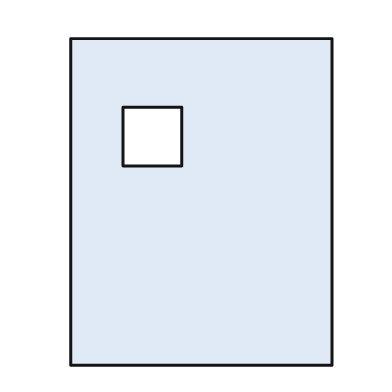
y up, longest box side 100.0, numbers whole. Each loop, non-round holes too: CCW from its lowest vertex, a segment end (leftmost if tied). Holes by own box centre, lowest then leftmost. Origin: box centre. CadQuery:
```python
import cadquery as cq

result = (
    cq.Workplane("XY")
    .moveTo(-40.0, -50.0)
    .lineTo(40.0, -50.0)
    .lineTo(40.0, 50.0)
    .lineTo(-40.0, 50.0)
    .close()
    .moveTo(-24.0, 11.0)
    .lineTo(-6.0, 11.0)
    .lineTo(-6.0, 29.0)
    .lineTo(-24.0, 29.0)
    .close()
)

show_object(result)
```